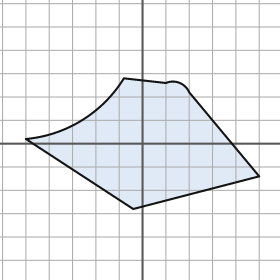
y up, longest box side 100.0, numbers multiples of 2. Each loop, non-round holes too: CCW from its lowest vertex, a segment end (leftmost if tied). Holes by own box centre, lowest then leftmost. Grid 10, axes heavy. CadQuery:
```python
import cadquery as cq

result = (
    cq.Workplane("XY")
    .moveTo(-4.0, -28.0)
    .lineTo(50.0, -14.0)
    .lineTo(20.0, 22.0)
    .threePointArc((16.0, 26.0), (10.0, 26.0))
    .lineTo(-8.0, 28.0)
    .threePointArc((-26.0, 10.0), (-50.0, 2.0))
    .close()
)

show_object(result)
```